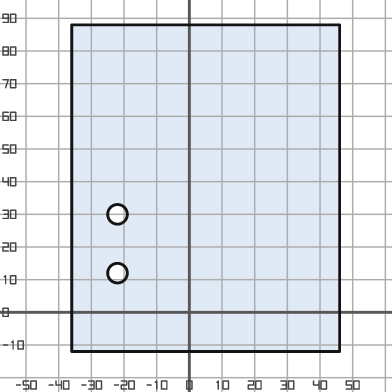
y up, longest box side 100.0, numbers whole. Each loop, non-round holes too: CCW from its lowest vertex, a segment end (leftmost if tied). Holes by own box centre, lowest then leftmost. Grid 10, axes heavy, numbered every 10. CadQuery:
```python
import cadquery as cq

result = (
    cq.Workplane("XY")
    .moveTo(-36.0, -12.0)
    .lineTo(46.0, -12.0)
    .lineTo(46.0, 88.0)
    .lineTo(-36.0, 88.0)
    .close()
    .moveTo(-22.0, 12.0)
    .circle(3.0)
    .moveTo(-22.0, 30.0)
    .circle(3.0)
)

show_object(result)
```